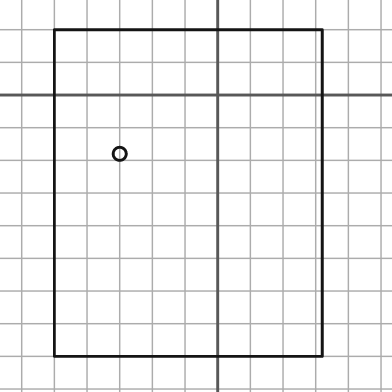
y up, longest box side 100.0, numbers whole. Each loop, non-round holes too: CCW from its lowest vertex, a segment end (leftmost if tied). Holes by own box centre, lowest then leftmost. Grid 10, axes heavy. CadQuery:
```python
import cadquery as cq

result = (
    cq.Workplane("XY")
    .moveTo(-50.0, -80.0)
    .lineTo(32.0, -80.0)
    .lineTo(32.0, 20.0)
    .lineTo(-50.0, 20.0)
    .close()
    .moveTo(-30.0, -18.0)
    .circle(2.0)
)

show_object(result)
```